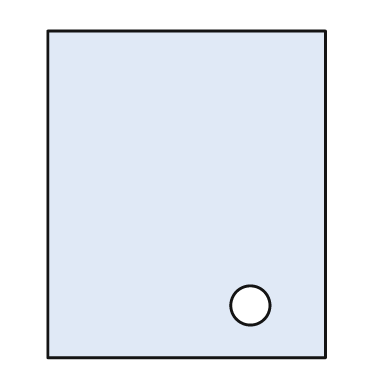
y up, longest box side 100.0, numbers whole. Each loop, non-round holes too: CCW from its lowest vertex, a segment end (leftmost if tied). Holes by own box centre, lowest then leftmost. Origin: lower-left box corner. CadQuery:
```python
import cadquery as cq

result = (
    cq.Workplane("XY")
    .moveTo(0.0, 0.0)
    .lineTo(85.0, 0.0)
    .lineTo(85.0, 100.0)
    .lineTo(0.0, 100.0)
    .close()
    .moveTo(62.0, 16.0)
    .circle(6.0)
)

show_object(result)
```